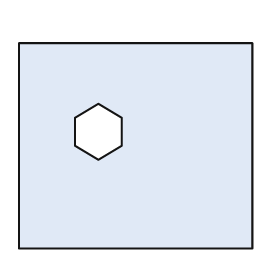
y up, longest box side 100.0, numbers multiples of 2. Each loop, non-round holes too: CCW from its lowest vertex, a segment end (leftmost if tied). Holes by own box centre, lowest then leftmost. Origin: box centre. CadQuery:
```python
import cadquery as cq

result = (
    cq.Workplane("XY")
    .moveTo(-50.0, -44.0)
    .lineTo(50.0, -44.0)
    .lineTo(50.0, 44.0)
    .lineTo(-50.0, 44.0)
    .close()
    .moveTo(-16.0, -6.0)
    .lineTo(-6.0, 0.0)
    .lineTo(-6.0, 12.0)
    .lineTo(-16.0, 18.0)
    .lineTo(-26.0, 12.0)
    .lineTo(-26.0, 0.0)
    .close()
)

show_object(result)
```